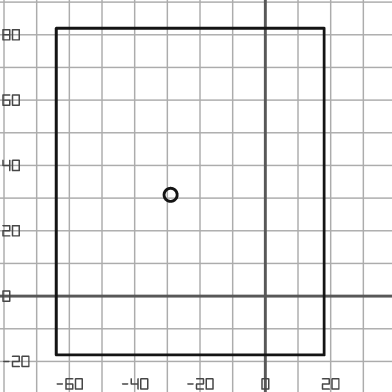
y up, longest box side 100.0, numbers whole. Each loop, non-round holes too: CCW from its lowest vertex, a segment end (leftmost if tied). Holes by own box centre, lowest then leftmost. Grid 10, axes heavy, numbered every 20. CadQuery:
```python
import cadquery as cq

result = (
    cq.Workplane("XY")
    .moveTo(-64.0, -18.0)
    .lineTo(18.0, -18.0)
    .lineTo(18.0, 82.0)
    .lineTo(-64.0, 82.0)
    .close()
    .moveTo(-29.0, 31.0)
    .circle(2.0)
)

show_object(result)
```